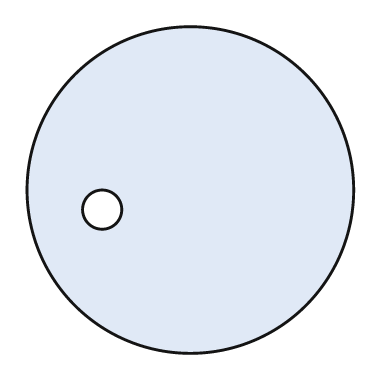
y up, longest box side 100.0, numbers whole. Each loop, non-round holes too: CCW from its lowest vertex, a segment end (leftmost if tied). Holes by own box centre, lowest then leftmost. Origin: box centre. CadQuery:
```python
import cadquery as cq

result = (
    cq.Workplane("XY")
    .moveTo(0.0, 0.0)
    .circle(50.0)
    .moveTo(-27.0, -6.0)
    .circle(6.0)
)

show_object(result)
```